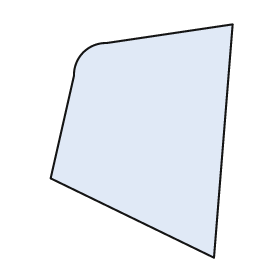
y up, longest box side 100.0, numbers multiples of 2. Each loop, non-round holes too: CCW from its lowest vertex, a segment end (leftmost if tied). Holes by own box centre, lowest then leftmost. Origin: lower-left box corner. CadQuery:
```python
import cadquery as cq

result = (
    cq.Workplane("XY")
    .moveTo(70.0, 0.0)
    .lineTo(78.0, 100.0)
    .lineTo(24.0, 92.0)
    .threePointArc((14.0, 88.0), (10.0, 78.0))
    .lineTo(0.0, 34.0)
    .close()
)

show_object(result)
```